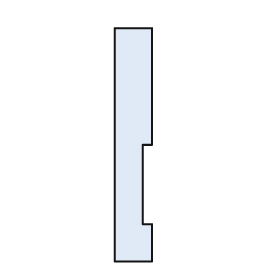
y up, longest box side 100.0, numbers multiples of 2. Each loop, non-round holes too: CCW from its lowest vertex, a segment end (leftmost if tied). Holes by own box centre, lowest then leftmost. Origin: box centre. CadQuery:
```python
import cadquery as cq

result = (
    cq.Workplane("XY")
    .moveTo(-8.0, -50.0)
    .lineTo(8.0, -50.0)
    .lineTo(8.0, -34.0)
    .lineTo(4.0, -34.0)
    .lineTo(4.0, 0.0)
    .lineTo(8.0, 0.0)
    .lineTo(8.0, 50.0)
    .lineTo(-8.0, 50.0)
    .close()
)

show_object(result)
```